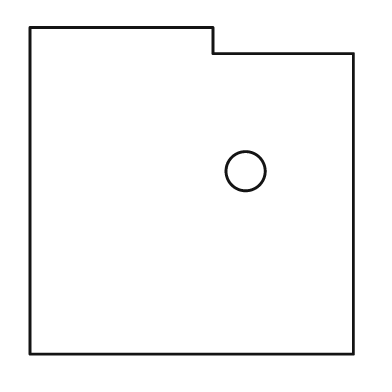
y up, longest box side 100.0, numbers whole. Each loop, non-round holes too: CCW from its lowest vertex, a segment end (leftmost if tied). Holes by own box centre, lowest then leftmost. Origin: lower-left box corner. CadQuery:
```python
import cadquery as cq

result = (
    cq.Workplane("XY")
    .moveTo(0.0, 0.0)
    .lineTo(99.0, 0.0)
    .lineTo(99.0, 92.0)
    .lineTo(56.0, 92.0)
    .lineTo(56.0, 100.0)
    .lineTo(0.0, 100.0)
    .close()
    .moveTo(66.0, 56.0)
    .circle(6.0)
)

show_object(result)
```